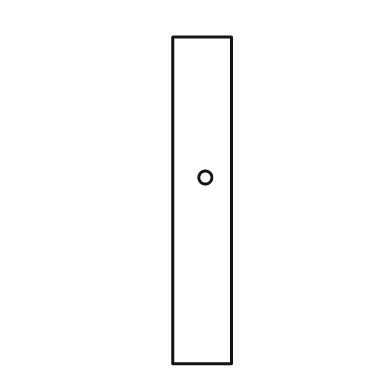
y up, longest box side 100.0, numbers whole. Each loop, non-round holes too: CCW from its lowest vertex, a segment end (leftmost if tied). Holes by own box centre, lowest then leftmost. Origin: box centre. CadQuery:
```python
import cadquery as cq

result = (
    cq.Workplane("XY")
    .moveTo(-9.0, -50.0)
    .lineTo(9.0, -50.0)
    .lineTo(9.0, 50.0)
    .lineTo(-9.0, 50.0)
    .close()
    .moveTo(1.0, 7.0)
    .circle(2.0)
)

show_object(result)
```